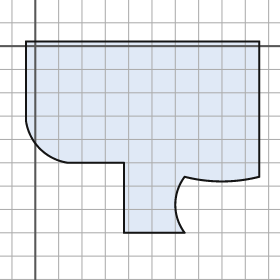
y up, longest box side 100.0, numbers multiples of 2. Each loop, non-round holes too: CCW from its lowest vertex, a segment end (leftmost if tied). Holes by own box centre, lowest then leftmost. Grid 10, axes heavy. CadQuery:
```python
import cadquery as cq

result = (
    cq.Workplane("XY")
    .moveTo(38.0, -80.0)
    .lineTo(64.0, -80.0)
    .threePointArc((60.0, -68.0), (64.0, -56.0))
    .threePointArc((80.0, -58.0), (96.0, -56.0))
    .lineTo(96.0, 2.0)
    .lineTo(-4.0, 2.0)
    .lineTo(-4.0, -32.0)
    .threePointArc((2.0, -44.0), (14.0, -50.0))
    .lineTo(38.0, -50.0)
    .close()
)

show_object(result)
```